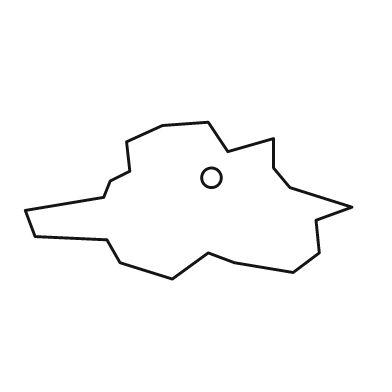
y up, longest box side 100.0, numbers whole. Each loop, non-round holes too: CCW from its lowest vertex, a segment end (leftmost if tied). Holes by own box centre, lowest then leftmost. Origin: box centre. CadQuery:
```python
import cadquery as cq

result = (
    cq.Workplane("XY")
    .moveTo(-5.0, -24.0)
    .lineTo(6.0, -16.0)
    .lineTo(14.0, -19.0)
    .lineTo(32.0, -22.0)
    .lineTo(40.0, -16.0)
    .lineTo(39.0, -6.0)
    .lineTo(50.0, -2.0)
    .lineTo(31.0, 4.0)
    .lineTo(26.0, 10.0)
    .lineTo(26.0, 19.0)
    .lineTo(12.0, 15.0)
    .lineTo(6.0, 24.0)
    .lineTo(-8.0, 23.0)
    .lineTo(-19.0, 18.0)
    .lineTo(-18.0, 9.0)
    .lineTo(-24.0, 6.0)
    .lineTo(-26.0, 1.0)
    .lineTo(-50.0, -3.0)
    .lineTo(-47.0, -11.0)
    .lineTo(-25.0, -12.0)
    .lineTo(-21.0, -19.0)
    .close()
    .moveTo(7.0, 7.0)
    .circle(3.0)
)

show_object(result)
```